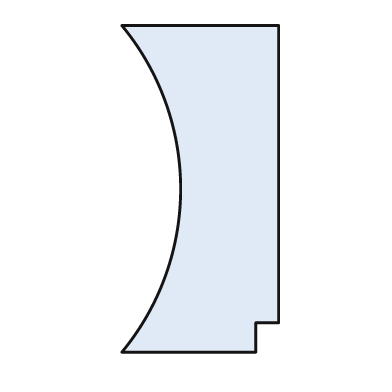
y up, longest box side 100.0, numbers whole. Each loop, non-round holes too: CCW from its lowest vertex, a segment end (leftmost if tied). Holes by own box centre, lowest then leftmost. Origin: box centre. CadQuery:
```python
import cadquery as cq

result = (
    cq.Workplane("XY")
    .moveTo(-24.0, -50.0)
    .lineTo(17.0, -50.0)
    .lineTo(17.0, -41.0)
    .lineTo(24.0, -41.0)
    .lineTo(24.0, 50.0)
    .lineTo(-24.0, 50.0)
    .threePointArc((-6.0, 0.0), (-24.0, -50.0))
    .close()
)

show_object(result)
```